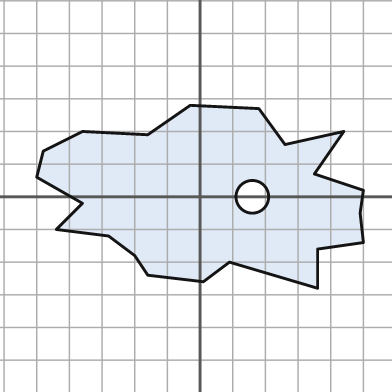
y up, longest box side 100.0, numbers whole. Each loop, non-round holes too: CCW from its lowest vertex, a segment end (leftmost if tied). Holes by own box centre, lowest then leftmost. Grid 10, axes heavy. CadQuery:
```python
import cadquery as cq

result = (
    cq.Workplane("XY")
    .moveTo(36.0, -28.0)
    .lineTo(36.0, -16.0)
    .lineTo(50.0, -14.0)
    .lineTo(49.0, -5.0)
    .lineTo(50.0, 2.0)
    .lineTo(35.0, 7.0)
    .lineTo(44.0, 20.0)
    .lineTo(26.0, 16.0)
    .lineTo(18.0, 27.0)
    .lineTo(-3.0, 28.0)
    .lineTo(-16.0, 19.0)
    .lineTo(-36.0, 20.0)
    .lineTo(-48.0, 14.0)
    .lineTo(-50.0, 6.0)
    .lineTo(-36.0, -2.0)
    .lineTo(-44.0, -10.0)
    .lineTo(-28.0, -12.0)
    .lineTo(-20.0, -18.0)
    .lineTo(-16.0, -24.0)
    .lineTo(1.0, -26.0)
    .lineTo(9.0, -20.0)
    .close()
    .moveTo(16.0, 0.0)
    .circle(5.0)
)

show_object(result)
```